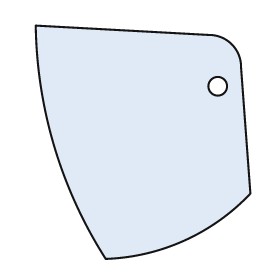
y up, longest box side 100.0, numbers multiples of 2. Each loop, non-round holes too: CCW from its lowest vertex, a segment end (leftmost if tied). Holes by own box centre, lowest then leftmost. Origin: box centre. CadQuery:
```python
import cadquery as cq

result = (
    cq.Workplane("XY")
    .moveTo(-16.0, -50.0)
    .threePointArc((18.0, -42.0), (46.0, -22.0))
    .lineTo(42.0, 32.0)
    .threePointArc((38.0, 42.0), (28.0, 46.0))
    .lineTo(-46.0, 50.0)
    .threePointArc((-38.0, -2.0), (-16.0, -50.0))
    .close()
    .moveTo(32.0, 24.0)
    .circle(4.0)
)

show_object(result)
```